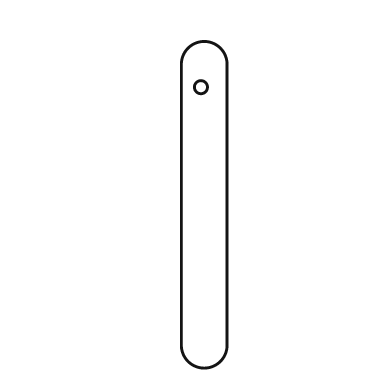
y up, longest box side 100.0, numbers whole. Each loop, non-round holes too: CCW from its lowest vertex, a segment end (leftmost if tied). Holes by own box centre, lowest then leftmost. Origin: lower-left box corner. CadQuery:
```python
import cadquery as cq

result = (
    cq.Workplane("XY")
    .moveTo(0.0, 7.0)
    .threePointArc((7.0, 0.0), (14.0, 7.0))
    .lineTo(14.0, 93.0)
    .threePointArc((7.0, 100.0), (0.0, 93.0))
    .close()
    .moveTo(6.0, 86.0)
    .circle(2.0)
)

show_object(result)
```